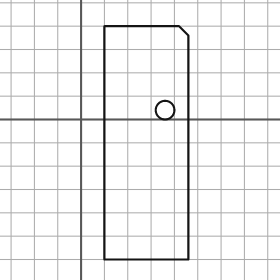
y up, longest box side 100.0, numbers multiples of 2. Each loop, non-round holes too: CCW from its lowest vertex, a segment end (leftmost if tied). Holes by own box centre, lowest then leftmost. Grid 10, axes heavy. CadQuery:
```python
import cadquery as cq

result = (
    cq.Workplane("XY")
    .moveTo(10.0, -60.0)
    .lineTo(46.0, -60.0)
    .lineTo(46.0, 36.0)
    .lineTo(42.0, 40.0)
    .lineTo(10.0, 40.0)
    .close()
    .moveTo(36.0, 4.0)
    .circle(4.0)
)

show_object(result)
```